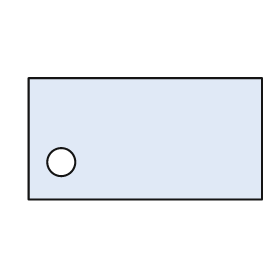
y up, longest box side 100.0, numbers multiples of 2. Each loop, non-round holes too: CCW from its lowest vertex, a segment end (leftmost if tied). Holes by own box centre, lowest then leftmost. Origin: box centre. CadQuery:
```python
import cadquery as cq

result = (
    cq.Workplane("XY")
    .moveTo(-50.0, -26.0)
    .lineTo(50.0, -26.0)
    .lineTo(50.0, 26.0)
    .lineTo(-50.0, 26.0)
    .close()
    .moveTo(-36.0, -10.0)
    .circle(6.0)
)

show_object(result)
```